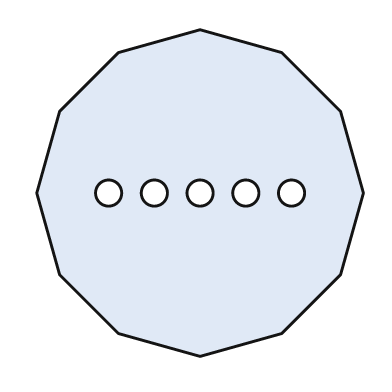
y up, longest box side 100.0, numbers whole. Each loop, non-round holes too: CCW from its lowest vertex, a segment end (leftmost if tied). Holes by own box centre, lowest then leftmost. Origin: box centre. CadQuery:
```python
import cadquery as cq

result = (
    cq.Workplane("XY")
    .moveTo(0.0, -50.0)
    .lineTo(25.0, -43.0)
    .lineTo(43.0, -25.0)
    .lineTo(50.0, 0.0)
    .lineTo(43.0, 25.0)
    .lineTo(25.0, 43.0)
    .lineTo(0.0, 50.0)
    .lineTo(-25.0, 43.0)
    .lineTo(-43.0, 25.0)
    .lineTo(-50.0, 0.0)
    .lineTo(-43.0, -25.0)
    .lineTo(-25.0, -43.0)
    .close()
    .moveTo(-28.0, 0.0)
    .circle(4.0)
    .moveTo(-14.0, 0.0)
    .circle(4.0)
    .moveTo(0.0, 0.0)
    .circle(4.0)
    .moveTo(14.0, 0.0)
    .circle(4.0)
    .moveTo(28.0, 0.0)
    .circle(4.0)
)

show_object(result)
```